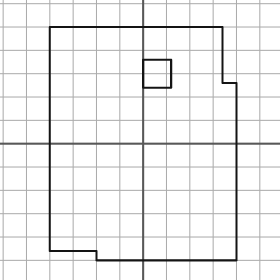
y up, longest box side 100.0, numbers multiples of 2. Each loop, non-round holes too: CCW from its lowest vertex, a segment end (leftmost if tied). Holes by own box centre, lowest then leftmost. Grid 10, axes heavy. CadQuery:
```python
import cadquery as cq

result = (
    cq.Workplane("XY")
    .moveTo(-20.0, -50.0)
    .lineTo(40.0, -50.0)
    .lineTo(40.0, 26.0)
    .lineTo(34.0, 26.0)
    .lineTo(34.0, 50.0)
    .lineTo(-40.0, 50.0)
    .lineTo(-40.0, -46.0)
    .lineTo(-20.0, -46.0)
    .close()
    .moveTo(0.0, 24.0)
    .lineTo(12.0, 24.0)
    .lineTo(12.0, 36.0)
    .lineTo(0.0, 36.0)
    .close()
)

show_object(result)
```